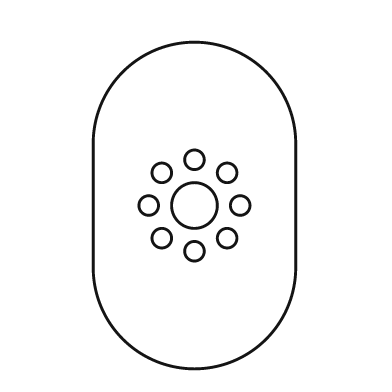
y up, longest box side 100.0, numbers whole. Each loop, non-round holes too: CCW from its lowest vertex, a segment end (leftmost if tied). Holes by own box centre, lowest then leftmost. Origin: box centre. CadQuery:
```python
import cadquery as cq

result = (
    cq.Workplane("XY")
    .moveTo(-31.0, -19.0)
    .threePointArc((0.0, -50.0), (31.0, -19.0))
    .lineTo(31.0, 19.0)
    .threePointArc((0.0, 50.0), (-31.0, 19.0))
    .close()
    .moveTo(0.0, -14.0)
    .circle(3.0)
    .moveTo(-10.0, -10.0)
    .circle(3.0)
    .moveTo(10.0, -10.0)
    .circle(3.0)
    .moveTo(-14.0, 0.0)
    .circle(3.0)
    .moveTo(0.0, 0.0)
    .circle(7.0)
    .moveTo(14.0, 0.0)
    .circle(3.0)
    .moveTo(-10.0, 10.0)
    .circle(3.0)
    .moveTo(10.0, 10.0)
    .circle(3.0)
    .moveTo(0.0, 14.0)
    .circle(3.0)
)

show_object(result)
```